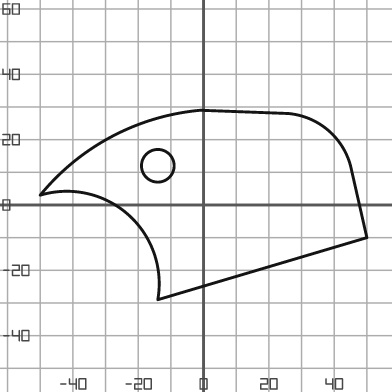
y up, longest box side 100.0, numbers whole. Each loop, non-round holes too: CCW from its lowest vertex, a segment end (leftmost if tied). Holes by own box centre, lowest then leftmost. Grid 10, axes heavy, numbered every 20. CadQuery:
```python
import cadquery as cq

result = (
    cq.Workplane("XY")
    .moveTo(-14.0, -29.0)
    .lineTo(50.0, -10.0)
    .lineTo(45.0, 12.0)
    .threePointArc((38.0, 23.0), (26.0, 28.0))
    .lineTo(-1.0, 29.0)
    .threePointArc((-28.0, 21.0), (-50.0, 3.0))
    .threePointArc((-23.0, -3.0), (-14.0, -29.0))
    .close()
    .moveTo(-14.0, 12.0)
    .circle(5.0)
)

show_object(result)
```